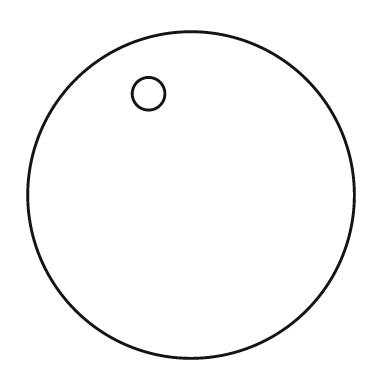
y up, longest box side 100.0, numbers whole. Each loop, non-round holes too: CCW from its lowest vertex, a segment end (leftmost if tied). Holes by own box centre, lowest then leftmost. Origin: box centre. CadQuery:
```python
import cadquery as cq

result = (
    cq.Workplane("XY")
    .moveTo(0.0, 0.0)
    .circle(50.0)
    .moveTo(-13.0, 31.0)
    .circle(5.0)
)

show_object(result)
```